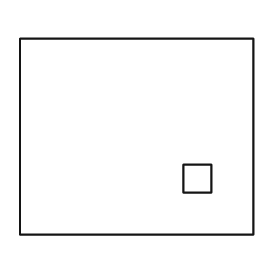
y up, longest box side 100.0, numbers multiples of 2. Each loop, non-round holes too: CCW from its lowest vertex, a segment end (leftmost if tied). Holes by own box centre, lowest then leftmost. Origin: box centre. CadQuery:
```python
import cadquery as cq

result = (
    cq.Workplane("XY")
    .moveTo(-50.0, -42.0)
    .lineTo(50.0, -42.0)
    .lineTo(50.0, 42.0)
    .lineTo(-50.0, 42.0)
    .close()
    .moveTo(20.0, -24.0)
    .lineTo(32.0, -24.0)
    .lineTo(32.0, -12.0)
    .lineTo(20.0, -12.0)
    .close()
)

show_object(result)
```